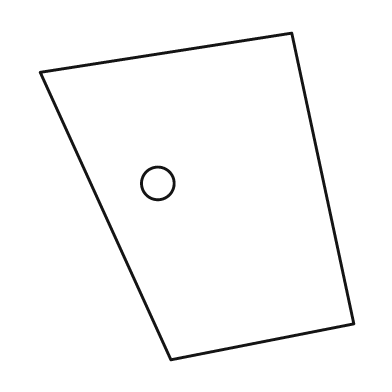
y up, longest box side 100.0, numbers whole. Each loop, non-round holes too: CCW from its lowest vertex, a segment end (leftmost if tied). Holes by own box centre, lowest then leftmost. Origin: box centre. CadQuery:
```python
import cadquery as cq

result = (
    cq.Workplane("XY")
    .moveTo(-8.0, -50.0)
    .lineTo(48.0, -39.0)
    .lineTo(29.0, 50.0)
    .lineTo(-48.0, 38.0)
    .close()
    .moveTo(-12.0, 4.0)
    .circle(5.0)
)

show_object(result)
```